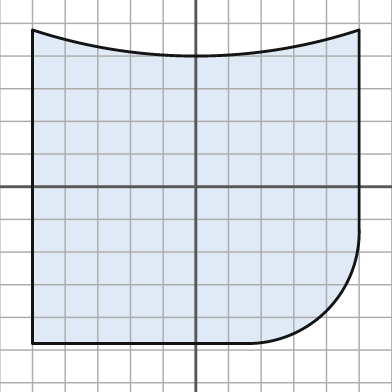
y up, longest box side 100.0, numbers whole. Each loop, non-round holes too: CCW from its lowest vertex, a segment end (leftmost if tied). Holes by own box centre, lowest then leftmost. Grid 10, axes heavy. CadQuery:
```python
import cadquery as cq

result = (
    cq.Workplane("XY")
    .moveTo(-50.0, -48.0)
    .lineTo(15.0, -48.0)
    .threePointArc((40.0, -38.0), (50.0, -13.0))
    .lineTo(50.0, 48.0)
    .threePointArc((0.0, 40.0), (-50.0, 48.0))
    .close()
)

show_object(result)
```